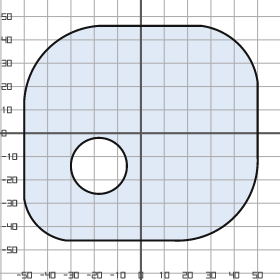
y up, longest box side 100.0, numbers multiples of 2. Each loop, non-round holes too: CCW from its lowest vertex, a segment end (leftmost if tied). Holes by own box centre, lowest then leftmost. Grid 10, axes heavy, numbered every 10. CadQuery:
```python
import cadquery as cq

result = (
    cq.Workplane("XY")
    .moveTo(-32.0, -46.0)
    .lineTo(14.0, -46.0)
    .threePointArc((40.0, -36.0), (50.0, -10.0))
    .lineTo(50.0, 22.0)
    .threePointArc((42.0, 38.0), (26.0, 46.0))
    .lineTo(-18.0, 46.0)
    .threePointArc((-40.0, 36.0), (-50.0, 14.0))
    .lineTo(-50.0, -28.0)
    .threePointArc((-44.0, -40.0), (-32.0, -46.0))
    .close()
    .moveTo(-18.0, -14.0)
    .circle(12.0)
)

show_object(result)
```